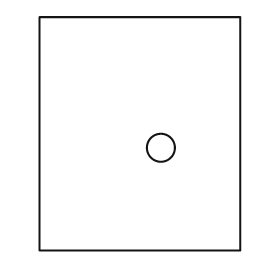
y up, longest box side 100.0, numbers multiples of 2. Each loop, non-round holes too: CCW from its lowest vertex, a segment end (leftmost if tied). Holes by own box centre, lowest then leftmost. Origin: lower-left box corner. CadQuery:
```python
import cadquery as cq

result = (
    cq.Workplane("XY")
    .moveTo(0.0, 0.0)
    .lineTo(86.0, 0.0)
    .lineTo(86.0, 100.0)
    .lineTo(0.0, 100.0)
    .close()
    .moveTo(52.0, 44.0)
    .circle(6.0)
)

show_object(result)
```